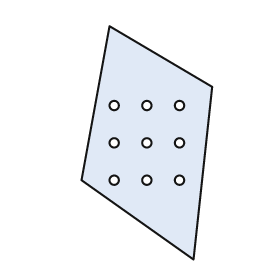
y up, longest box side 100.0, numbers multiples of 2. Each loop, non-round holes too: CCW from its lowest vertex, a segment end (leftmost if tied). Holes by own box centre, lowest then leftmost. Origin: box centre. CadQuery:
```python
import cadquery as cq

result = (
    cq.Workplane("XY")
    .moveTo(20.0, -50.0)
    .lineTo(28.0, 24.0)
    .lineTo(-16.0, 50.0)
    .lineTo(-28.0, -16.0)
    .close()
    .moveTo(-14.0, -16.0)
    .circle(2.0)
    .moveTo(0.0, -16.0)
    .circle(2.0)
    .moveTo(14.0, -16.0)
    .circle(2.0)
    .moveTo(-14.0, 0.0)
    .circle(2.0)
    .moveTo(0.0, 0.0)
    .circle(2.0)
    .moveTo(14.0, 0.0)
    .circle(2.0)
    .moveTo(-14.0, 16.0)
    .circle(2.0)
    .moveTo(0.0, 16.0)
    .circle(2.0)
    .moveTo(14.0, 16.0)
    .circle(2.0)
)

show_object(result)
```